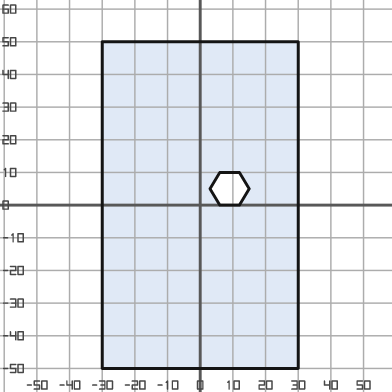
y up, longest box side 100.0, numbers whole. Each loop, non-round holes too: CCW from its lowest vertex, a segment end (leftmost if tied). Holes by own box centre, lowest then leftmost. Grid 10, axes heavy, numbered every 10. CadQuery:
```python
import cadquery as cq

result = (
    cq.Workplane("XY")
    .moveTo(-30.0, -50.0)
    .lineTo(30.0, -50.0)
    .lineTo(30.0, 50.0)
    .lineTo(-30.0, 50.0)
    .close()
    .moveTo(6.0, 0.0)
    .lineTo(12.0, 0.0)
    .lineTo(15.0, 5.0)
    .lineTo(12.0, 10.0)
    .lineTo(6.0, 10.0)
    .lineTo(3.0, 5.0)
    .close()
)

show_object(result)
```